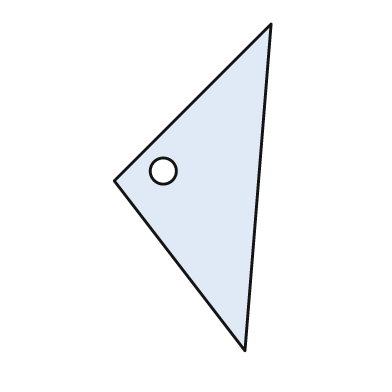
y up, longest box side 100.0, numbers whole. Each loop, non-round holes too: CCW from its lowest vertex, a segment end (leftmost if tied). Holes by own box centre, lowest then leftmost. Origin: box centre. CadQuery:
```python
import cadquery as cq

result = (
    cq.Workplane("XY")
    .moveTo(16.0, -50.0)
    .lineTo(24.0, 50.0)
    .lineTo(-24.0, 2.0)
    .close()
    .moveTo(-9.0, 5.0)
    .circle(4.0)
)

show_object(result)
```